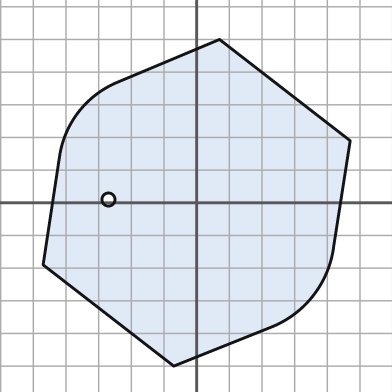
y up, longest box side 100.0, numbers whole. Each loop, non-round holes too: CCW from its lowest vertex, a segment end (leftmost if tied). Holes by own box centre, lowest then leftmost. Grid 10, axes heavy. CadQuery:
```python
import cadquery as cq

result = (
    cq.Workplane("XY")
    .moveTo(-7.0, -50.0)
    .lineTo(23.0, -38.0)
    .threePointArc((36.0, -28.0), (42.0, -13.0))
    .lineTo(47.0, 19.0)
    .lineTo(7.0, 50.0)
    .lineTo(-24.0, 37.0)
    .threePointArc((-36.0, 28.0), (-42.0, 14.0))
    .lineTo(-47.0, -19.0)
    .close()
    .moveTo(-27.0, 1.0)
    .circle(2.0)
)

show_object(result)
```